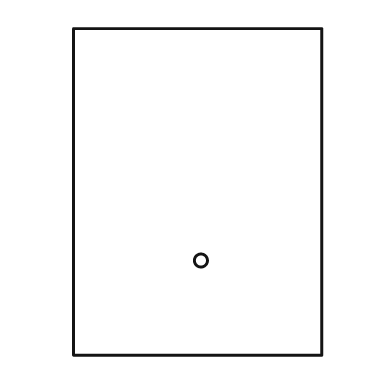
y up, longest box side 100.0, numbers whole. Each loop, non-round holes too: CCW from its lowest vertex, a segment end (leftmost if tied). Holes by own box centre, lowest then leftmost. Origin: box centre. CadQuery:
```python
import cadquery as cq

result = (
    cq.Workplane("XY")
    .moveTo(-38.0, -50.0)
    .lineTo(38.0, -50.0)
    .lineTo(38.0, 50.0)
    .lineTo(-38.0, 50.0)
    .close()
    .moveTo(1.0, -21.0)
    .circle(2.0)
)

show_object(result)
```